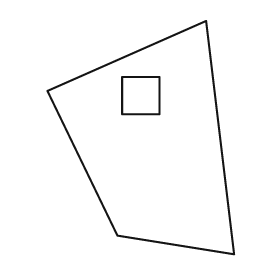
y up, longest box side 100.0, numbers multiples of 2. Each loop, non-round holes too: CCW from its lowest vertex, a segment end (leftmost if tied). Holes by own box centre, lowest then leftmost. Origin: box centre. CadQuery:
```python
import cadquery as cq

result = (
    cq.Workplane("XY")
    .moveTo(40.0, -50.0)
    .lineTo(28.0, 50.0)
    .lineTo(-40.0, 20.0)
    .lineTo(-10.0, -42.0)
    .close()
    .moveTo(-8.0, 10.0)
    .lineTo(8.0, 10.0)
    .lineTo(8.0, 26.0)
    .lineTo(-8.0, 26.0)
    .close()
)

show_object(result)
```